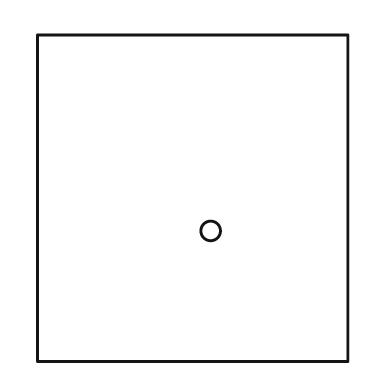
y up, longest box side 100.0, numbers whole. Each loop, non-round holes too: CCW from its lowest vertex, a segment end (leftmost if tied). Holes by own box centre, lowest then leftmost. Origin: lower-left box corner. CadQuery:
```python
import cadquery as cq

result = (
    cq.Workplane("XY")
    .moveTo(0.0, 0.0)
    .lineTo(95.0, 0.0)
    .lineTo(95.0, 100.0)
    .lineTo(0.0, 100.0)
    .close()
    .moveTo(53.0, 40.0)
    .circle(3.0)
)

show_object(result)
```